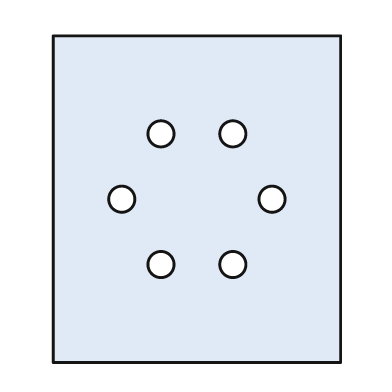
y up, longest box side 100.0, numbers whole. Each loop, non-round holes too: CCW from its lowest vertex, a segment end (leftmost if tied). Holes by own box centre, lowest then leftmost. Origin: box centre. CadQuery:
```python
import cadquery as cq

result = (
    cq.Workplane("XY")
    .moveTo(-44.0, -50.0)
    .lineTo(44.0, -50.0)
    .lineTo(44.0, 50.0)
    .lineTo(-44.0, 50.0)
    .close()
    .moveTo(-11.0, -20.0)
    .circle(4.0)
    .moveTo(11.0, -20.0)
    .circle(4.0)
    .moveTo(-23.0, 0.0)
    .circle(4.0)
    .moveTo(23.0, 0.0)
    .circle(4.0)
    .moveTo(-11.0, 20.0)
    .circle(4.0)
    .moveTo(11.0, 20.0)
    .circle(4.0)
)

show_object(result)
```